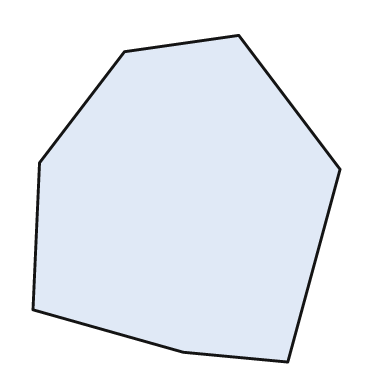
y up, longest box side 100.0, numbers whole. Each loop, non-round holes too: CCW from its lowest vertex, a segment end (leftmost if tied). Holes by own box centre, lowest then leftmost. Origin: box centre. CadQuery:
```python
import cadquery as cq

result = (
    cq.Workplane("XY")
    .moveTo(31.0, -50.0)
    .lineTo(47.0, 9.0)
    .lineTo(16.0, 50.0)
    .lineTo(-19.0, 45.0)
    .lineTo(-45.0, 11.0)
    .lineTo(-47.0, -34.0)
    .lineTo(-1.0, -47.0)
    .close()
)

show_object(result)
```